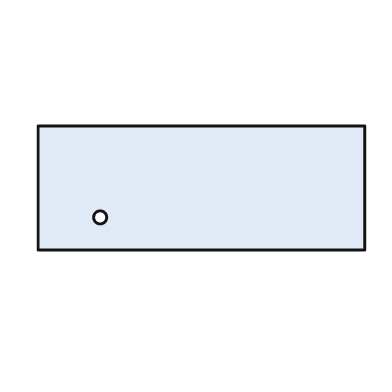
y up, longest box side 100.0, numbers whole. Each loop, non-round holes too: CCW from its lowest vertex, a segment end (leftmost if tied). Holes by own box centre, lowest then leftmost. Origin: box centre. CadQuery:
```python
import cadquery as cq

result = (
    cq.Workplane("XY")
    .moveTo(-50.0, -19.0)
    .lineTo(50.0, -19.0)
    .lineTo(50.0, 19.0)
    .lineTo(-50.0, 19.0)
    .close()
    .moveTo(-31.0, -9.0)
    .circle(2.0)
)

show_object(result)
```